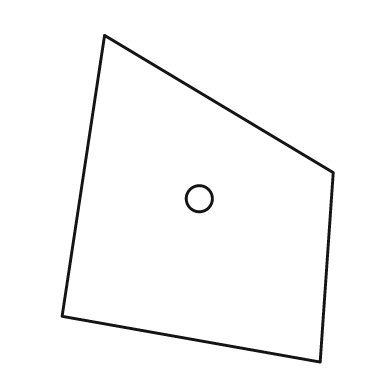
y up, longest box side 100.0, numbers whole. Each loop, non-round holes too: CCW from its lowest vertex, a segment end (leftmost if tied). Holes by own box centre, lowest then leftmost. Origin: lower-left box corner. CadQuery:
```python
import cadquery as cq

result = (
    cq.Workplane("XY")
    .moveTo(79.0, 0.0)
    .lineTo(83.0, 58.0)
    .lineTo(13.0, 100.0)
    .lineTo(0.0, 14.0)
    .close()
    .moveTo(42.0, 50.0)
    .circle(4.0)
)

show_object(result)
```